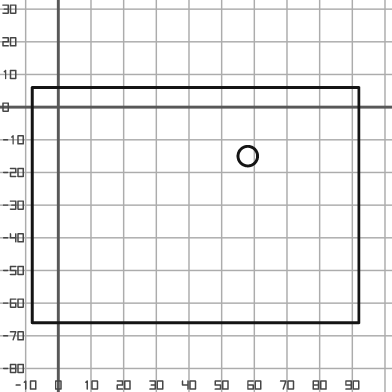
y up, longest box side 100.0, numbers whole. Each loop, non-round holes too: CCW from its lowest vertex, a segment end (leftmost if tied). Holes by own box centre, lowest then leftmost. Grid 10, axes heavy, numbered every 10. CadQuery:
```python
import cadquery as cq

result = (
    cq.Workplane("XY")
    .moveTo(-8.0, -66.0)
    .lineTo(92.0, -66.0)
    .lineTo(92.0, 6.0)
    .lineTo(-8.0, 6.0)
    .close()
    .moveTo(58.0, -15.0)
    .circle(3.0)
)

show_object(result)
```